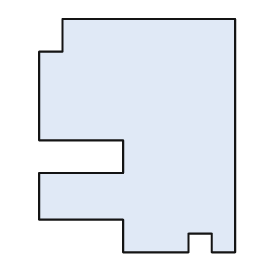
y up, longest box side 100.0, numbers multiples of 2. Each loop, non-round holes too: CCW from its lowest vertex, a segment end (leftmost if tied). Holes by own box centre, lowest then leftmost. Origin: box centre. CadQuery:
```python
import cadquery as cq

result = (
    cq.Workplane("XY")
    .moveTo(-6.0, -50.0)
    .lineTo(22.0, -50.0)
    .lineTo(22.0, -42.0)
    .lineTo(32.0, -42.0)
    .lineTo(32.0, -50.0)
    .lineTo(42.0, -50.0)
    .lineTo(42.0, 50.0)
    .lineTo(-32.0, 50.0)
    .lineTo(-32.0, 36.0)
    .lineTo(-42.0, 36.0)
    .lineTo(-42.0, -2.0)
    .lineTo(-6.0, -2.0)
    .lineTo(-6.0, -16.0)
    .lineTo(-42.0, -16.0)
    .lineTo(-42.0, -36.0)
    .lineTo(-6.0, -36.0)
    .close()
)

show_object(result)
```